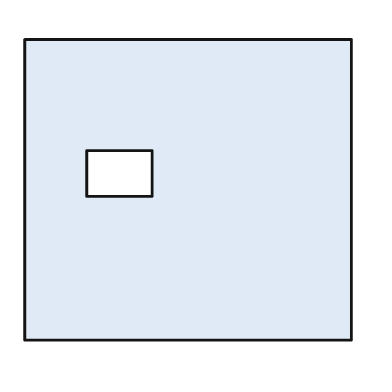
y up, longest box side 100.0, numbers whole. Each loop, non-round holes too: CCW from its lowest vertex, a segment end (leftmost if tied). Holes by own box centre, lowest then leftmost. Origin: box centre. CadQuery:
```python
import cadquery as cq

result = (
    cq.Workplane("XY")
    .moveTo(-50.0, -46.0)
    .lineTo(50.0, -46.0)
    .lineTo(50.0, 46.0)
    .lineTo(-50.0, 46.0)
    .close()
    .moveTo(-31.0, -2.0)
    .lineTo(-11.0, -2.0)
    .lineTo(-11.0, 12.0)
    .lineTo(-31.0, 12.0)
    .close()
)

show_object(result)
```